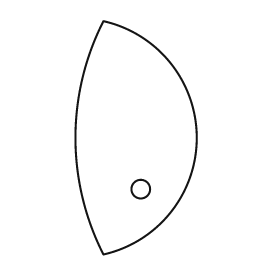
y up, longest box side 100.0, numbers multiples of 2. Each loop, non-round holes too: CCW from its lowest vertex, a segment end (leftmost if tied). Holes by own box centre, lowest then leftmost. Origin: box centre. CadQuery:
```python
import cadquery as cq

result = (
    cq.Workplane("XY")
    .moveTo(-14.0, -50.0)
    .threePointArc((26.0, 0.0), (-14.0, 50.0))
    .threePointArc((-26.0, 0.0), (-14.0, -50.0))
    .close()
    .moveTo(2.0, -22.0)
    .circle(4.0)
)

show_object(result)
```